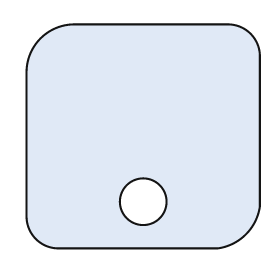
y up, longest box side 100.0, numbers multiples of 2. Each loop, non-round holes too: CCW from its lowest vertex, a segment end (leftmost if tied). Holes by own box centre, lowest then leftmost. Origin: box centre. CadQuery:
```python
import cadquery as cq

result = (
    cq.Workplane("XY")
    .moveTo(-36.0, -48.0)
    .lineTo(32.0, -48.0)
    .threePointArc((44.0, -42.0), (50.0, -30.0))
    .lineTo(50.0, 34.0)
    .threePointArc((46.0, 44.0), (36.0, 48.0))
    .lineTo(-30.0, 48.0)
    .threePointArc((-44.0, 42.0), (-50.0, 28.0))
    .lineTo(-50.0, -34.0)
    .threePointArc((-46.0, -44.0), (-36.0, -48.0))
    .close()
    .moveTo(0.0, -28.0)
    .circle(10.0)
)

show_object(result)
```